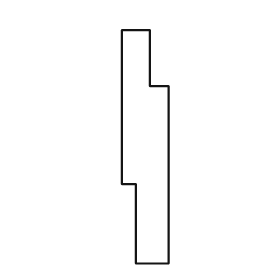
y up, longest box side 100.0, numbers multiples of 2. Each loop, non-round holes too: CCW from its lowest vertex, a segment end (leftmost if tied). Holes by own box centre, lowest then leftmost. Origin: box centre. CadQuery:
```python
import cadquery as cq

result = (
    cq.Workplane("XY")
    .moveTo(-4.0, -50.0)
    .lineTo(10.0, -50.0)
    .lineTo(10.0, 26.0)
    .lineTo(2.0, 26.0)
    .lineTo(2.0, 50.0)
    .lineTo(-10.0, 50.0)
    .lineTo(-10.0, -16.0)
    .lineTo(-4.0, -16.0)
    .close()
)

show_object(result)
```